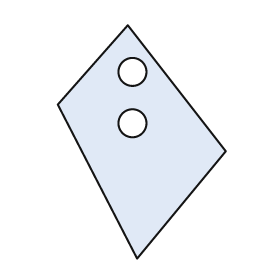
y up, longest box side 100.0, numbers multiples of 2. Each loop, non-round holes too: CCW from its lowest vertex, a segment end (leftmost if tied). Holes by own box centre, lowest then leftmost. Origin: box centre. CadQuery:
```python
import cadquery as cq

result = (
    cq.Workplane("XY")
    .moveTo(-2.0, -50.0)
    .lineTo(36.0, -4.0)
    .lineTo(-6.0, 50.0)
    .lineTo(-36.0, 16.0)
    .close()
    .moveTo(-4.0, 8.0)
    .circle(6.0)
    .moveTo(-4.0, 30.0)
    .circle(6.0)
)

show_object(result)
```